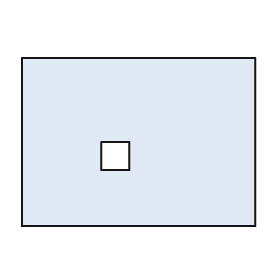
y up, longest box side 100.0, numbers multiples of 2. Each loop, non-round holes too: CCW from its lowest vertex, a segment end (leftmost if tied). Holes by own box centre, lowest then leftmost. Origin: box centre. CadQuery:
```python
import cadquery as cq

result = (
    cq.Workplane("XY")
    .moveTo(-50.0, -36.0)
    .lineTo(50.0, -36.0)
    .lineTo(50.0, 36.0)
    .lineTo(-50.0, 36.0)
    .close()
    .moveTo(-16.0, -12.0)
    .lineTo(-4.0, -12.0)
    .lineTo(-4.0, 0.0)
    .lineTo(-16.0, 0.0)
    .close()
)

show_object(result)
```